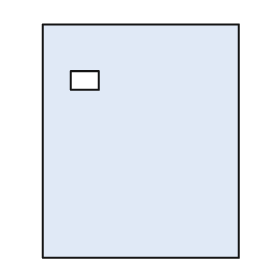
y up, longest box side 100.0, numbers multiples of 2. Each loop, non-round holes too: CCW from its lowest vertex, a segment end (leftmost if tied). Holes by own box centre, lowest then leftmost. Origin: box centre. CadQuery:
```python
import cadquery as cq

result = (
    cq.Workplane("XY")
    .moveTo(-42.0, -50.0)
    .lineTo(42.0, -50.0)
    .lineTo(42.0, 50.0)
    .lineTo(-42.0, 50.0)
    .close()
    .moveTo(-30.0, 22.0)
    .lineTo(-18.0, 22.0)
    .lineTo(-18.0, 30.0)
    .lineTo(-30.0, 30.0)
    .close()
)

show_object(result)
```